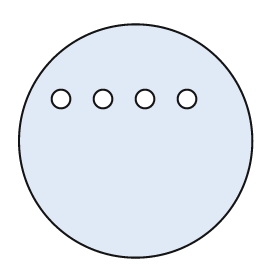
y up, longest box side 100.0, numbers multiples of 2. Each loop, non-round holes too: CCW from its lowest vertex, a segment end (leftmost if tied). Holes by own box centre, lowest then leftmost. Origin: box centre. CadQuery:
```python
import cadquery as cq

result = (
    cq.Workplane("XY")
    .moveTo(0.0, 0.0)
    .circle(50.0)
    .moveTo(-32.0, 18.0)
    .circle(4.0)
    .moveTo(-14.0, 18.0)
    .circle(4.0)
    .moveTo(4.0, 18.0)
    .circle(4.0)
    .moveTo(22.0, 18.0)
    .circle(4.0)
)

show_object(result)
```